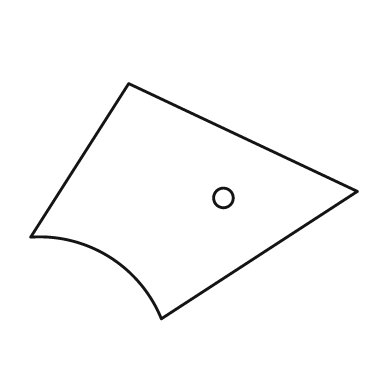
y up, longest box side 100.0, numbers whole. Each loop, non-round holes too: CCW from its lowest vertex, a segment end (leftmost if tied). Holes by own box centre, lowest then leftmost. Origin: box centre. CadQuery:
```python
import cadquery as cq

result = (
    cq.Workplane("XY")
    .moveTo(-10.0, -36.0)
    .lineTo(50.0, 3.0)
    .lineTo(-20.0, 36.0)
    .lineTo(-50.0, -11.0)
    .threePointArc((-26.0, -17.0), (-10.0, -36.0))
    .close()
    .moveTo(9.0, 1.0)
    .circle(3.0)
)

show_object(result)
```